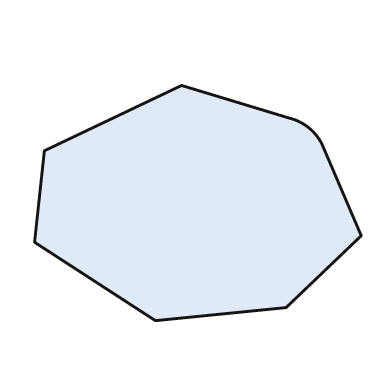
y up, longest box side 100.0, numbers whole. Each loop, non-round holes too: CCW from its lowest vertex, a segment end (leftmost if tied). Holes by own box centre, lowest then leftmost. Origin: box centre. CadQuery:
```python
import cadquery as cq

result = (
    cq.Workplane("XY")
    .moveTo(-13.0, -36.0)
    .lineTo(27.0, -32.0)
    .lineTo(50.0, -10.0)
    .lineTo(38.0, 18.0)
    .threePointArc((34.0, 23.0), (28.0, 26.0))
    .lineTo(-5.0, 36.0)
    .lineTo(-47.0, 16.0)
    .lineTo(-50.0, -12.0)
    .close()
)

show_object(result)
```